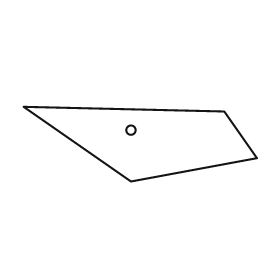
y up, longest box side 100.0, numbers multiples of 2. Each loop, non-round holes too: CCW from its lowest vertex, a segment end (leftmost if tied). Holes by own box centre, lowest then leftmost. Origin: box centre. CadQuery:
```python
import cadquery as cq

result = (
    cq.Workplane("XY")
    .moveTo(-4.0, -16.0)
    .lineTo(50.0, -6.0)
    .lineTo(36.0, 14.0)
    .lineTo(-50.0, 16.0)
    .close()
    .moveTo(-4.0, 6.0)
    .circle(2.0)
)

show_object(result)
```